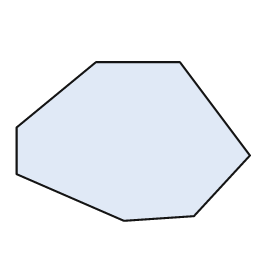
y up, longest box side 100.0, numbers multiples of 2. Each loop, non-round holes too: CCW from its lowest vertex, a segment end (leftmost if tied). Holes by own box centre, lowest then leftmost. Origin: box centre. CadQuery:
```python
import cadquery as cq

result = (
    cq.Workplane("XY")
    .moveTo(-4.0, -34.0)
    .lineTo(26.0, -32.0)
    .lineTo(50.0, -6.0)
    .lineTo(20.0, 34.0)
    .lineTo(-16.0, 34.0)
    .lineTo(-50.0, 6.0)
    .lineTo(-50.0, -14.0)
    .close()
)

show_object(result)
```